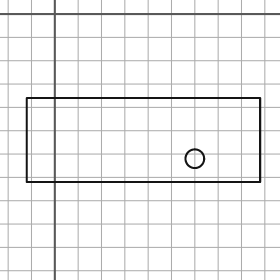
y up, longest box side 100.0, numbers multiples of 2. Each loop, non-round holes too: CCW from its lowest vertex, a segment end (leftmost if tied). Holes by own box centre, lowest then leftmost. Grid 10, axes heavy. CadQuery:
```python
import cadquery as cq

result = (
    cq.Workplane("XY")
    .moveTo(-12.0, -72.0)
    .lineTo(88.0, -72.0)
    .lineTo(88.0, -36.0)
    .lineTo(-12.0, -36.0)
    .close()
    .moveTo(60.0, -62.0)
    .circle(4.0)
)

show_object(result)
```